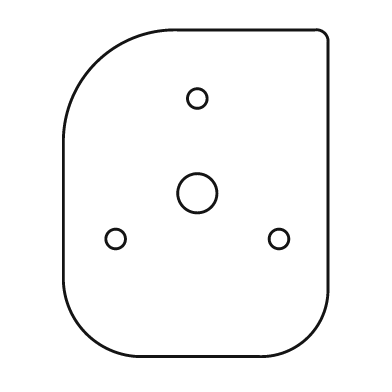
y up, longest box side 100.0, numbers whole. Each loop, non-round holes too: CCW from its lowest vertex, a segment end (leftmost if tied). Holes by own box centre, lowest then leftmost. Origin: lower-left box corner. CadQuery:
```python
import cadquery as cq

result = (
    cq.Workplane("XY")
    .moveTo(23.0, 0.0)
    .lineTo(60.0, 0.0)
    .threePointArc((75.0, 6.0), (81.0, 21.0))
    .lineTo(81.0, 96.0)
    .threePointArc((80.0, 99.0), (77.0, 100.0))
    .lineTo(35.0, 100.0)
    .threePointArc((10.0, 90.0), (0.0, 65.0))
    .lineTo(0.0, 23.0)
    .threePointArc((7.0, 7.0), (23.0, 0.0))
    .close()
    .moveTo(16.0, 36.0)
    .circle(3.0)
    .moveTo(66.0, 36.0)
    .circle(3.0)
    .moveTo(41.0, 50.0)
    .circle(6.0)
    .moveTo(41.0, 79.0)
    .circle(3.0)
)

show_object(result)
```